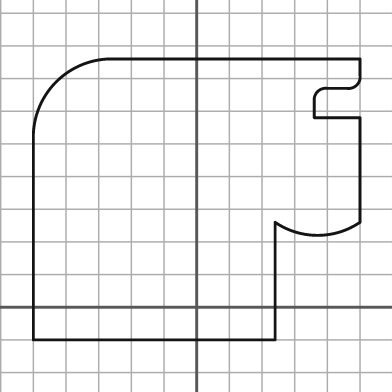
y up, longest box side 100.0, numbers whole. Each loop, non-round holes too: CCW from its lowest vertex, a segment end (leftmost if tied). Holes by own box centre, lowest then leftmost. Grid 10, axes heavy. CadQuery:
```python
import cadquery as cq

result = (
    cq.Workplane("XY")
    .moveTo(-50.0, -10.0)
    .lineTo(24.0, -10.0)
    .lineTo(24.0, 26.0)
    .threePointArc((37.0, 22.0), (50.0, 26.0))
    .lineTo(50.0, 58.0)
    .lineTo(36.0, 58.0)
    .lineTo(36.0, 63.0)
    .threePointArc((37.0, 66.0), (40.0, 67.0))
    .lineTo(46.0, 67.0)
    .threePointArc((49.0, 68.0), (50.0, 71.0))
    .lineTo(50.0, 76.0)
    .lineTo(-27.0, 76.0)
    .threePointArc((-43.0, 69.0), (-50.0, 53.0))
    .close()
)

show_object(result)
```